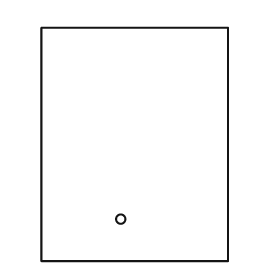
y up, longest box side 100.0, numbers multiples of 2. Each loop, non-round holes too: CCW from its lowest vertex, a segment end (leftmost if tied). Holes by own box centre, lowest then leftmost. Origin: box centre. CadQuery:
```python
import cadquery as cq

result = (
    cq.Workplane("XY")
    .moveTo(-40.0, -50.0)
    .lineTo(40.0, -50.0)
    .lineTo(40.0, 50.0)
    .lineTo(-40.0, 50.0)
    .close()
    .moveTo(-6.0, -32.0)
    .circle(2.0)
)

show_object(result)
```